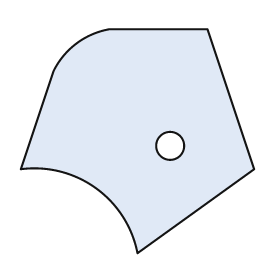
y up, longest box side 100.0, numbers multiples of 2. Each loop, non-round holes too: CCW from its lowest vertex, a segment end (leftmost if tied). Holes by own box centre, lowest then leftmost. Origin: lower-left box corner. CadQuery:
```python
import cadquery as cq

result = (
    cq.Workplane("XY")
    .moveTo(50.0, 0.0)
    .lineTo(100.0, 36.0)
    .lineTo(80.0, 96.0)
    .lineTo(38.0, 96.0)
    .threePointArc((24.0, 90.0), (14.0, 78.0))
    .lineTo(0.0, 36.0)
    .threePointArc((32.0, 28.0), (50.0, 0.0))
    .close()
    .moveTo(64.0, 46.0)
    .circle(6.0)
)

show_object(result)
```